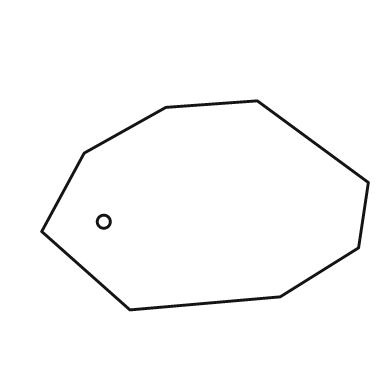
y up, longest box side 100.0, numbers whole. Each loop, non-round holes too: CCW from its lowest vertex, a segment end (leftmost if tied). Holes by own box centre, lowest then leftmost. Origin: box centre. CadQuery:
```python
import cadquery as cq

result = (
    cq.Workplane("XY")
    .moveTo(-23.0, -32.0)
    .lineTo(23.0, -28.0)
    .lineTo(47.0, -13.0)
    .lineTo(50.0, 7.0)
    .lineTo(16.0, 32.0)
    .lineTo(-12.0, 30.0)
    .lineTo(-37.0, 16.0)
    .lineTo(-50.0, -8.0)
    .close()
    .moveTo(-31.0, -5.0)
    .circle(2.0)
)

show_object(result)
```